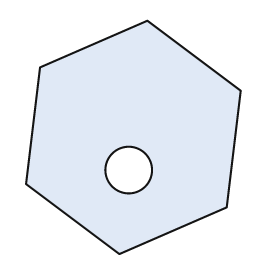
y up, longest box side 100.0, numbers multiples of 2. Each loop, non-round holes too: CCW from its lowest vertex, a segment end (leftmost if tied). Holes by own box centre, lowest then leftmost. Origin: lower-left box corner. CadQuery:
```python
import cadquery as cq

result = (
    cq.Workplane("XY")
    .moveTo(40.0, 0.0)
    .lineTo(86.0, 20.0)
    .lineTo(92.0, 70.0)
    .lineTo(52.0, 100.0)
    .lineTo(6.0, 80.0)
    .lineTo(0.0, 30.0)
    .close()
    .moveTo(44.0, 36.0)
    .circle(10.0)
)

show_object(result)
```